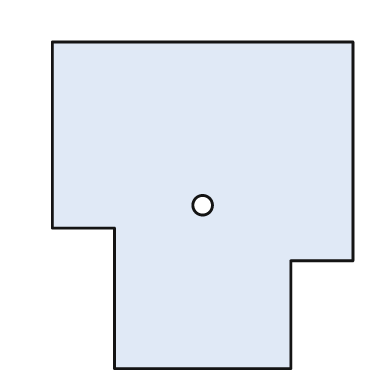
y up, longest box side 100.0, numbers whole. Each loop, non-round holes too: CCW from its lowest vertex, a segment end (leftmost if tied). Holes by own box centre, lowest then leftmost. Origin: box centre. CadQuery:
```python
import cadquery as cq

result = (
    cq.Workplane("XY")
    .moveTo(-27.0, -50.0)
    .lineTo(27.0, -50.0)
    .lineTo(27.0, -17.0)
    .lineTo(46.0, -17.0)
    .lineTo(46.0, 50.0)
    .lineTo(-46.0, 50.0)
    .lineTo(-46.0, -7.0)
    .lineTo(-27.0, -7.0)
    .close()
    .moveTo(0.0, 0.0)
    .circle(3.0)
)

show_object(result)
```